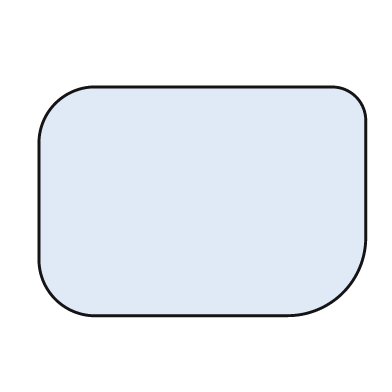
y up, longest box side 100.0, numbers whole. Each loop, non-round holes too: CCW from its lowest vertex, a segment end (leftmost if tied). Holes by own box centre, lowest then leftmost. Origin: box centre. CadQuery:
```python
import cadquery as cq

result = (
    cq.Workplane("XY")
    .moveTo(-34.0, -35.0)
    .lineTo(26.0, -35.0)
    .threePointArc((43.0, -28.0), (50.0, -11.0))
    .lineTo(50.0, 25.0)
    .threePointArc((47.0, 32.0), (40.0, 35.0))
    .lineTo(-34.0, 35.0)
    .threePointArc((-45.0, 30.0), (-50.0, 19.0))
    .lineTo(-50.0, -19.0)
    .threePointArc((-45.0, -30.0), (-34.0, -35.0))
    .close()
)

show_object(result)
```